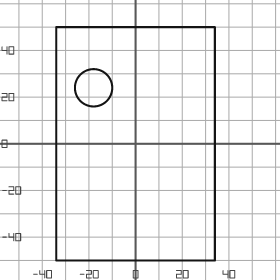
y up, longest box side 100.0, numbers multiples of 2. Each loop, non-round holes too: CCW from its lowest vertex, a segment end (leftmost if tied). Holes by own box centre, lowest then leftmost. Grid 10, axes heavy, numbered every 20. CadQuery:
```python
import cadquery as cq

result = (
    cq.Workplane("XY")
    .moveTo(-34.0, -50.0)
    .lineTo(34.0, -50.0)
    .lineTo(34.0, 50.0)
    .lineTo(-34.0, 50.0)
    .close()
    .moveTo(-18.0, 24.0)
    .circle(8.0)
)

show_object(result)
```